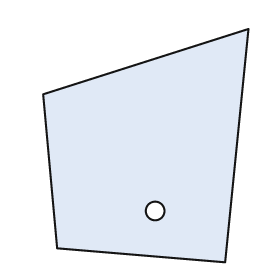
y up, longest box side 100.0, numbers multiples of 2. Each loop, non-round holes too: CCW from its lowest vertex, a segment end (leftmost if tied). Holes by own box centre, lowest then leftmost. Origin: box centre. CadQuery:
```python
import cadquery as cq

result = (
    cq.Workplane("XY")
    .moveTo(34.0, -50.0)
    .lineTo(44.0, 50.0)
    .lineTo(-44.0, 22.0)
    .lineTo(-38.0, -44.0)
    .close()
    .moveTo(4.0, -28.0)
    .circle(4.0)
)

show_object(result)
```